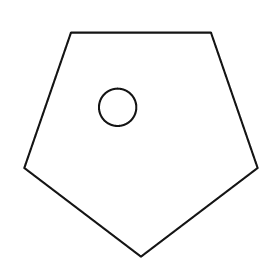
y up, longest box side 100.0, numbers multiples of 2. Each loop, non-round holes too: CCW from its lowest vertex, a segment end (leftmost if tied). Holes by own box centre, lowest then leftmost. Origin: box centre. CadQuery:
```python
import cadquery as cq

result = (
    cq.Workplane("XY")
    .moveTo(0.0, -48.0)
    .lineTo(50.0, -10.0)
    .lineTo(30.0, 48.0)
    .lineTo(-30.0, 48.0)
    .lineTo(-50.0, -10.0)
    .close()
    .moveTo(-10.0, 16.0)
    .circle(8.0)
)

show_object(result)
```